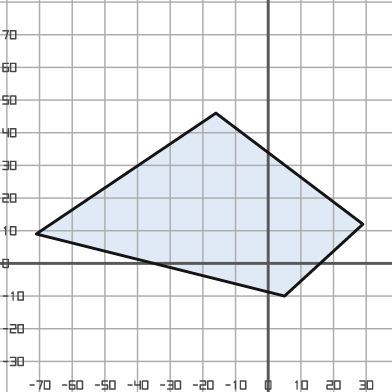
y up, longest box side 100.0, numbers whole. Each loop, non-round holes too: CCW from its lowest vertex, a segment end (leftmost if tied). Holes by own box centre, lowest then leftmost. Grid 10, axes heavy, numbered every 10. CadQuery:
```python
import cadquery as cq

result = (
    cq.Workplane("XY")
    .moveTo(5.0, -10.0)
    .lineTo(29.0, 12.0)
    .lineTo(-16.0, 46.0)
    .lineTo(-71.0, 9.0)
    .close()
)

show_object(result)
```